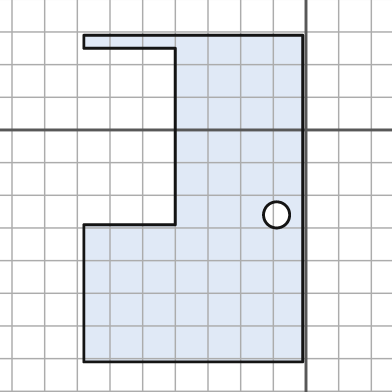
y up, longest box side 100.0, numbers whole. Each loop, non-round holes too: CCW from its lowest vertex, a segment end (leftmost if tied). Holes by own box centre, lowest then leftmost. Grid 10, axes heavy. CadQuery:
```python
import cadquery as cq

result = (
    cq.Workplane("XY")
    .moveTo(-68.0, -71.0)
    .lineTo(-1.0, -71.0)
    .lineTo(-1.0, 29.0)
    .lineTo(-68.0, 29.0)
    .lineTo(-68.0, 25.0)
    .lineTo(-40.0, 25.0)
    .lineTo(-40.0, -29.0)
    .lineTo(-68.0, -29.0)
    .close()
    .moveTo(-9.0, -26.0)
    .circle(4.0)
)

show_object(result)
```